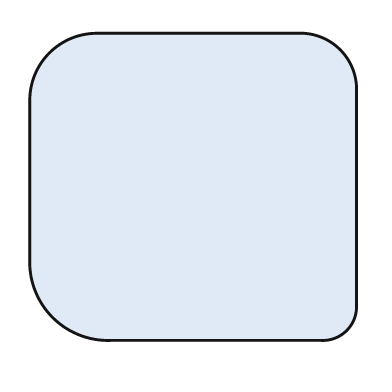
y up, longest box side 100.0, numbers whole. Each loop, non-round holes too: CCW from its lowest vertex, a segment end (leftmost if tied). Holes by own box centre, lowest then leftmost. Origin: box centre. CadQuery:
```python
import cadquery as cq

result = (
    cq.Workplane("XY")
    .moveTo(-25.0, -47.0)
    .lineTo(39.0, -47.0)
    .threePointArc((47.0, -44.0), (50.0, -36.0))
    .lineTo(50.0, 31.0)
    .threePointArc((45.0, 42.0), (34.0, 47.0))
    .lineTo(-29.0, 47.0)
    .threePointArc((-44.0, 41.0), (-50.0, 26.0))
    .lineTo(-50.0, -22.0)
    .threePointArc((-43.0, -40.0), (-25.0, -47.0))
    .close()
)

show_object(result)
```